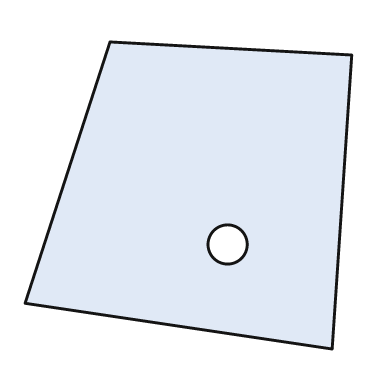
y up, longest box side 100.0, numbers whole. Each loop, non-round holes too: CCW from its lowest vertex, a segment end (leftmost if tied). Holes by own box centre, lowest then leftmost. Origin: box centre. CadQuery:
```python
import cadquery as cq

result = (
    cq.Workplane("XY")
    .moveTo(44.0, -47.0)
    .lineTo(50.0, 43.0)
    .lineTo(-24.0, 47.0)
    .lineTo(-50.0, -33.0)
    .close()
    .moveTo(12.0, -15.0)
    .circle(6.0)
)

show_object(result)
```